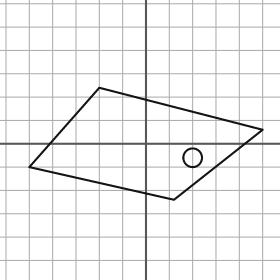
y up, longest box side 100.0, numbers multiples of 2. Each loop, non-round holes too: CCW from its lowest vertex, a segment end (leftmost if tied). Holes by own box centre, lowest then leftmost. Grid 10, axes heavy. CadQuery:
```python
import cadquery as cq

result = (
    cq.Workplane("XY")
    .moveTo(12.0, -24.0)
    .lineTo(50.0, 6.0)
    .lineTo(-20.0, 24.0)
    .lineTo(-50.0, -10.0)
    .close()
    .moveTo(20.0, -6.0)
    .circle(4.0)
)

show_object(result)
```